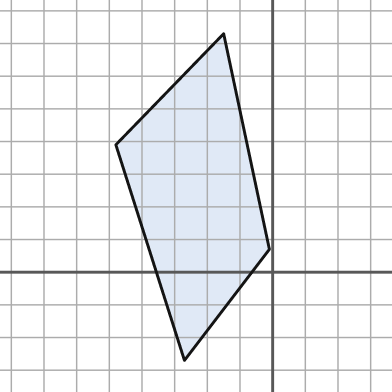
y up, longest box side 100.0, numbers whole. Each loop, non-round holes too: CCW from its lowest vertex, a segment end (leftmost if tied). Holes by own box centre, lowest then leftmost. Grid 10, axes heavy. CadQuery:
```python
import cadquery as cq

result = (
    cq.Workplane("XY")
    .moveTo(-27.0, -27.0)
    .lineTo(-1.0, 7.0)
    .lineTo(-15.0, 73.0)
    .lineTo(-48.0, 39.0)
    .close()
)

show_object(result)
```